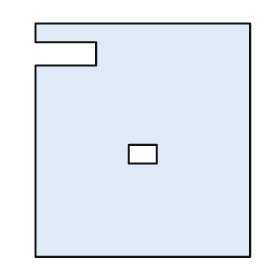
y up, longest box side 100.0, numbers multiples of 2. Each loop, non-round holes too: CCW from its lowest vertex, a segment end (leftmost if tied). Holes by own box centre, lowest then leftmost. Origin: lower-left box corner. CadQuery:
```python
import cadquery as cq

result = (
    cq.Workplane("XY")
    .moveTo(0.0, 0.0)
    .lineTo(92.0, 0.0)
    .lineTo(92.0, 100.0)
    .lineTo(0.0, 100.0)
    .lineTo(0.0, 92.0)
    .lineTo(26.0, 92.0)
    .lineTo(26.0, 82.0)
    .lineTo(0.0, 82.0)
    .close()
    .moveTo(40.0, 40.0)
    .lineTo(52.0, 40.0)
    .lineTo(52.0, 48.0)
    .lineTo(40.0, 48.0)
    .close()
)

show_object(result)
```